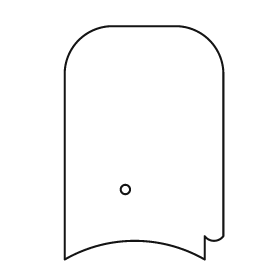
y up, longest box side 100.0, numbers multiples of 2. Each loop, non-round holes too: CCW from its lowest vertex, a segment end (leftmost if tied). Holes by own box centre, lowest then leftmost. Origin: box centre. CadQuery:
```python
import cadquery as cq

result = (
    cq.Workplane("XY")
    .moveTo(-34.0, -50.0)
    .threePointArc((-4.0, -42.0), (26.0, -50.0))
    .lineTo(26.0, -40.0)
    .threePointArc((30.0, -42.0), (34.0, -40.0))
    .lineTo(34.0, 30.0)
    .threePointArc((28.0, 44.0), (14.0, 50.0))
    .lineTo(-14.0, 50.0)
    .threePointArc((-28.0, 44.0), (-34.0, 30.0))
    .close()
    .moveTo(-8.0, -20.0)
    .circle(2.0)
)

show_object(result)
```